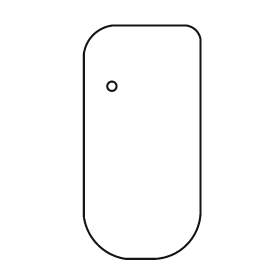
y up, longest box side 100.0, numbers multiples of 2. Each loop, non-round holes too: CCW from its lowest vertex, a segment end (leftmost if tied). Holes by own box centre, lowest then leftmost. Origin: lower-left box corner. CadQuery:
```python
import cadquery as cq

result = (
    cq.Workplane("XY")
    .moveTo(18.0, 0.0)
    .lineTo(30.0, 0.0)
    .threePointArc((44.0, 6.0), (50.0, 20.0))
    .lineTo(50.0, 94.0)
    .threePointArc((48.0, 98.0), (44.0, 100.0))
    .lineTo(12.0, 100.0)
    .threePointArc((4.0, 96.0), (0.0, 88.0))
    .lineTo(0.0, 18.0)
    .threePointArc((6.0, 6.0), (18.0, 0.0))
    .close()
    .moveTo(12.0, 74.0)
    .circle(2.0)
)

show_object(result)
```